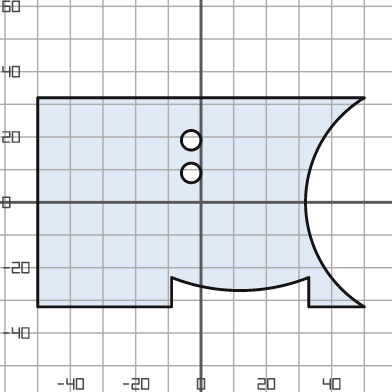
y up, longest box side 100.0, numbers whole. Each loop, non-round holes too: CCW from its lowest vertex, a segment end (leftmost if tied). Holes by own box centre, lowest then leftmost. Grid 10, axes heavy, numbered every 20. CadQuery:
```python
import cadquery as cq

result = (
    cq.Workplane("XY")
    .moveTo(-50.0, -32.0)
    .lineTo(-9.0, -32.0)
    .lineTo(-9.0, -23.0)
    .threePointArc((12.0, -27.0), (33.0, -23.0))
    .lineTo(33.0, -32.0)
    .lineTo(50.0, -32.0)
    .threePointArc((32.0, 0.0), (50.0, 32.0))
    .lineTo(-50.0, 32.0)
    .close()
    .moveTo(-3.0, 9.0)
    .circle(3.0)
    .moveTo(-3.0, 19.0)
    .circle(3.0)
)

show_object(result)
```